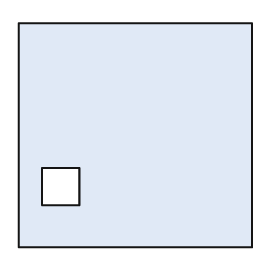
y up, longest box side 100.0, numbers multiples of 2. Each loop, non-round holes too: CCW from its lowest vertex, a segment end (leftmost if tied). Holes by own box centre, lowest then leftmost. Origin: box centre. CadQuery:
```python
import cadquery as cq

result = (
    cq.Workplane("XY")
    .moveTo(-50.0, -48.0)
    .lineTo(50.0, -48.0)
    .lineTo(50.0, 48.0)
    .lineTo(-50.0, 48.0)
    .close()
    .moveTo(-40.0, -30.0)
    .lineTo(-24.0, -30.0)
    .lineTo(-24.0, -14.0)
    .lineTo(-40.0, -14.0)
    .close()
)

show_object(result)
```